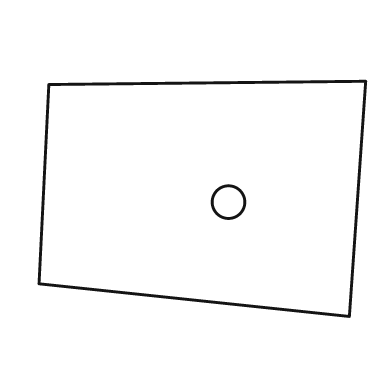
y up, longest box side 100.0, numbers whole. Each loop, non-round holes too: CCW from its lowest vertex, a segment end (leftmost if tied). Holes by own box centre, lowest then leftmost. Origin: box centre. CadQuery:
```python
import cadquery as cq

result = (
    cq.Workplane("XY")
    .moveTo(45.0, -36.0)
    .lineTo(50.0, 36.0)
    .lineTo(-47.0, 35.0)
    .lineTo(-50.0, -26.0)
    .close()
    .moveTo(8.0, -1.0)
    .circle(5.0)
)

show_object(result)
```